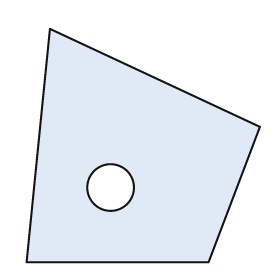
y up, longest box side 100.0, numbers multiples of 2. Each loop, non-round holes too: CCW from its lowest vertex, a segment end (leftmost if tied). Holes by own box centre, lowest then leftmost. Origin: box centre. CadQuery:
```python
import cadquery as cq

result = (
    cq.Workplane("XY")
    .moveTo(-50.0, -50.0)
    .lineTo(28.0, -50.0)
    .lineTo(50.0, 8.0)
    .lineTo(-40.0, 50.0)
    .close()
    .moveTo(-14.0, -18.0)
    .circle(10.0)
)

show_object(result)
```